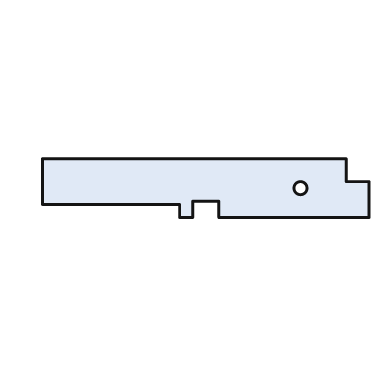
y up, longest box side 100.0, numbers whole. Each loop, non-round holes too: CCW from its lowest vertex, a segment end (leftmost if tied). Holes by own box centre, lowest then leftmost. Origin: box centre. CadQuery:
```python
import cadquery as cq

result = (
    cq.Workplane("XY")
    .moveTo(-8.0, -9.0)
    .lineTo(-4.0, -9.0)
    .lineTo(-4.0, -4.0)
    .lineTo(4.0, -4.0)
    .lineTo(4.0, -9.0)
    .lineTo(50.0, -9.0)
    .lineTo(50.0, 2.0)
    .lineTo(43.0, 2.0)
    .lineTo(43.0, 9.0)
    .lineTo(-50.0, 9.0)
    .lineTo(-50.0, -5.0)
    .lineTo(-8.0, -5.0)
    .close()
    .moveTo(29.0, 0.0)
    .circle(2.0)
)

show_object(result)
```